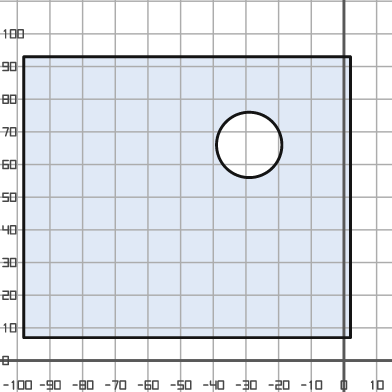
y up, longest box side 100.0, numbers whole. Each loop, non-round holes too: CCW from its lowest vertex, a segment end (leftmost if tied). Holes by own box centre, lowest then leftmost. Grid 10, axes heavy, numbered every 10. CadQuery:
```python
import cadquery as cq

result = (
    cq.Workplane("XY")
    .moveTo(-98.0, 7.0)
    .lineTo(2.0, 7.0)
    .lineTo(2.0, 93.0)
    .lineTo(-98.0, 93.0)
    .close()
    .moveTo(-29.0, 66.0)
    .circle(10.0)
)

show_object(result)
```